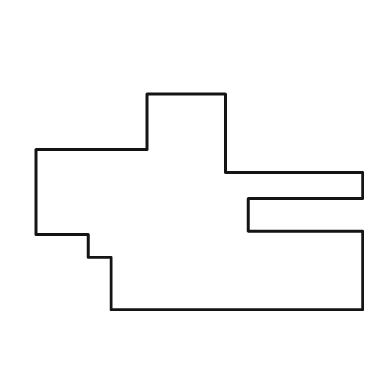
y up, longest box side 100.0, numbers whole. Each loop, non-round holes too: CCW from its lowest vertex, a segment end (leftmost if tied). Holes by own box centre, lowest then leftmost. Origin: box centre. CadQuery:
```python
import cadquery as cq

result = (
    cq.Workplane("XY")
    .moveTo(-27.0, -33.0)
    .lineTo(50.0, -33.0)
    .lineTo(50.0, -9.0)
    .lineTo(15.0, -9.0)
    .lineTo(15.0, 1.0)
    .lineTo(50.0, 1.0)
    .lineTo(50.0, 9.0)
    .lineTo(8.0, 9.0)
    .lineTo(8.0, 33.0)
    .lineTo(-16.0, 33.0)
    .lineTo(-16.0, 16.0)
    .lineTo(-50.0, 16.0)
    .lineTo(-50.0, -10.0)
    .lineTo(-34.0, -10.0)
    .lineTo(-34.0, -17.0)
    .lineTo(-27.0, -17.0)
    .close()
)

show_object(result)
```